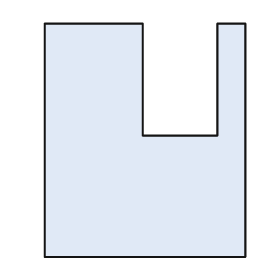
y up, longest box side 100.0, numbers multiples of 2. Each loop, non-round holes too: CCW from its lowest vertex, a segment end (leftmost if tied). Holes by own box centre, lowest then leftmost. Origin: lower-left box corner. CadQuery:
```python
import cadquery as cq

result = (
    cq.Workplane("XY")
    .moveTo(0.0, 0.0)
    .lineTo(86.0, 0.0)
    .lineTo(86.0, 100.0)
    .lineTo(74.0, 100.0)
    .lineTo(74.0, 52.0)
    .lineTo(42.0, 52.0)
    .lineTo(42.0, 100.0)
    .lineTo(0.0, 100.0)
    .close()
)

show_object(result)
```